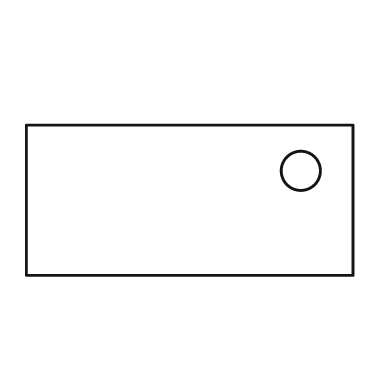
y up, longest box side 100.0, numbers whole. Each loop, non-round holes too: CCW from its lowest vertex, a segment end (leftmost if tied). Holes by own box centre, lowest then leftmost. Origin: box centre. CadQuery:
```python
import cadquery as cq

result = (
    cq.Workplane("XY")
    .moveTo(-50.0, -23.0)
    .lineTo(50.0, -23.0)
    .lineTo(50.0, 23.0)
    .lineTo(-50.0, 23.0)
    .close()
    .moveTo(34.0, 9.0)
    .circle(6.0)
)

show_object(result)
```